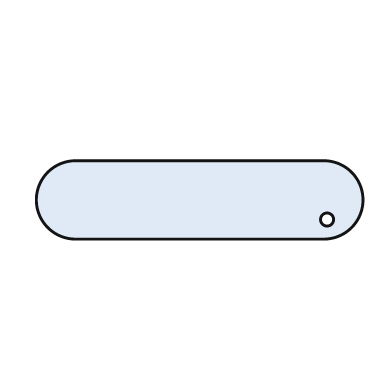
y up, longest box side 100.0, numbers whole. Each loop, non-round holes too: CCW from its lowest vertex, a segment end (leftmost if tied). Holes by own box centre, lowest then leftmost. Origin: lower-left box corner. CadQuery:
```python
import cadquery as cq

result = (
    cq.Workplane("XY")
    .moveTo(12.0, 0.0)
    .lineTo(88.0, 0.0)
    .threePointArc((100.0, 12.0), (88.0, 24.0))
    .lineTo(12.0, 24.0)
    .threePointArc((0.0, 12.0), (12.0, 0.0))
    .close()
    .moveTo(89.0, 6.0)
    .circle(2.0)
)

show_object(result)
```